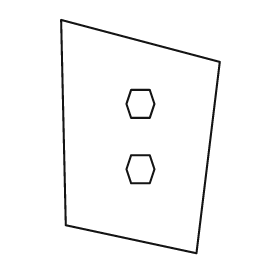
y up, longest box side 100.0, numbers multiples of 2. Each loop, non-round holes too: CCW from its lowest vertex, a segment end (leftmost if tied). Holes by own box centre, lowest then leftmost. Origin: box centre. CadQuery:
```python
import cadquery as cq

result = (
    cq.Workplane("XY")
    .moveTo(24.0, -50.0)
    .lineTo(34.0, 32.0)
    .lineTo(-34.0, 50.0)
    .lineTo(-32.0, -38.0)
    .close()
    .moveTo(-4.0, -20.0)
    .lineTo(4.0, -20.0)
    .lineTo(6.0, -14.0)
    .lineTo(4.0, -8.0)
    .lineTo(-4.0, -8.0)
    .lineTo(-6.0, -14.0)
    .close()
    .moveTo(-4.0, 8.0)
    .lineTo(4.0, 8.0)
    .lineTo(6.0, 14.0)
    .lineTo(4.0, 20.0)
    .lineTo(-4.0, 20.0)
    .lineTo(-6.0, 14.0)
    .close()
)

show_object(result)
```